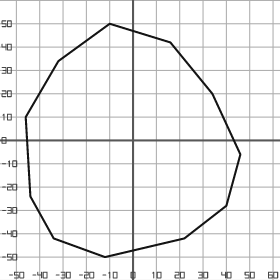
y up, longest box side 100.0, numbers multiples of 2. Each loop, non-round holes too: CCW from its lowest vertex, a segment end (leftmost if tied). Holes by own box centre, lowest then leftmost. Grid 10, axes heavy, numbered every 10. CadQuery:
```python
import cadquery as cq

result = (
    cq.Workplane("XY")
    .moveTo(-12.0, -50.0)
    .lineTo(22.0, -42.0)
    .lineTo(40.0, -28.0)
    .lineTo(46.0, -6.0)
    .lineTo(34.0, 20.0)
    .lineTo(16.0, 42.0)
    .lineTo(-10.0, 50.0)
    .lineTo(-32.0, 34.0)
    .lineTo(-46.0, 10.0)
    .lineTo(-44.0, -24.0)
    .lineTo(-34.0, -42.0)
    .close()
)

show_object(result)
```